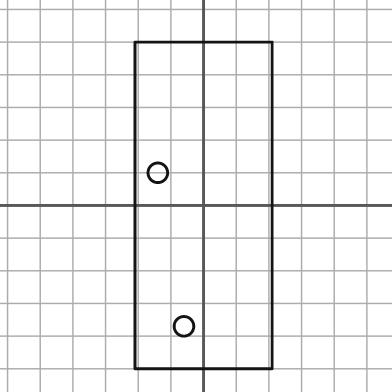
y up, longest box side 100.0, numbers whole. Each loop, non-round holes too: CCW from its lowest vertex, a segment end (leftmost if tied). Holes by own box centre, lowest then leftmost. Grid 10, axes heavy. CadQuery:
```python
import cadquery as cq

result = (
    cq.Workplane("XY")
    .moveTo(-21.0, -50.0)
    .lineTo(21.0, -50.0)
    .lineTo(21.0, 50.0)
    .lineTo(-21.0, 50.0)
    .close()
    .moveTo(-6.0, -37.0)
    .circle(3.0)
    .moveTo(-14.0, 10.0)
    .circle(3.0)
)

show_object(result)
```